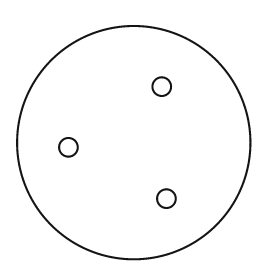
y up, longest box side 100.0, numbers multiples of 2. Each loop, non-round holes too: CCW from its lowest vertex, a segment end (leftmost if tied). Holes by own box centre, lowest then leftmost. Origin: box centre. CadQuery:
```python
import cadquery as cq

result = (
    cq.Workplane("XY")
    .moveTo(0.0, 0.0)
    .circle(50.0)
    .moveTo(14.0, -24.0)
    .circle(4.0)
    .moveTo(-28.0, -2.0)
    .circle(4.0)
    .moveTo(12.0, 24.0)
    .circle(4.0)
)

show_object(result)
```